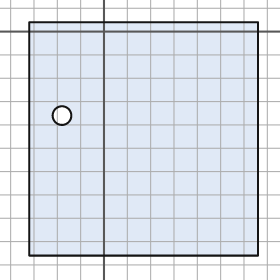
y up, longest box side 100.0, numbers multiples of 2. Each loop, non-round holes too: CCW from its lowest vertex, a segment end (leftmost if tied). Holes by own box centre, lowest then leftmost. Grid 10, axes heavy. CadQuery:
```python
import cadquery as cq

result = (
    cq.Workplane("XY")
    .moveTo(-32.0, -96.0)
    .lineTo(66.0, -96.0)
    .lineTo(66.0, 4.0)
    .lineTo(-32.0, 4.0)
    .close()
    .moveTo(-18.0, -36.0)
    .circle(4.0)
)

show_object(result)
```